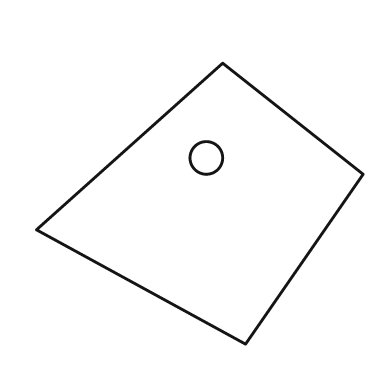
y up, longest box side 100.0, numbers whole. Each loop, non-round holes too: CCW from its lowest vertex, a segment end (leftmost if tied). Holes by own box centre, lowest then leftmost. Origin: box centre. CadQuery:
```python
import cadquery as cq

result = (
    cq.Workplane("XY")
    .moveTo(14.0, -43.0)
    .lineTo(50.0, 9.0)
    .lineTo(7.0, 43.0)
    .lineTo(-50.0, -8.0)
    .close()
    .moveTo(2.0, 14.0)
    .circle(5.0)
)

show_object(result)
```